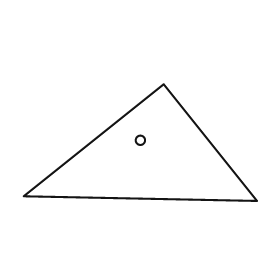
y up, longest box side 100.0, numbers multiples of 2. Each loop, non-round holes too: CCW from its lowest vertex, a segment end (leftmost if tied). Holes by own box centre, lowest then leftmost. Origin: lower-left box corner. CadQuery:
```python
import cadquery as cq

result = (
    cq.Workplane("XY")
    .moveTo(100.0, 0.0)
    .lineTo(60.0, 50.0)
    .lineTo(0.0, 2.0)
    .close()
    .moveTo(50.0, 26.0)
    .circle(2.0)
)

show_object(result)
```